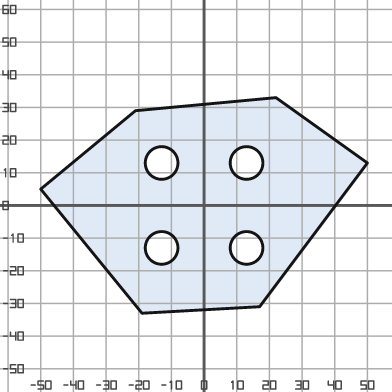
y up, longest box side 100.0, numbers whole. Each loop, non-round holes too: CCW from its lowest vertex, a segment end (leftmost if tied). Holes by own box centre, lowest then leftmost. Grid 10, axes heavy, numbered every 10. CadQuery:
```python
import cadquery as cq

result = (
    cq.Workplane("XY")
    .moveTo(-19.0, -33.0)
    .lineTo(17.0, -31.0)
    .lineTo(50.0, 13.0)
    .lineTo(22.0, 33.0)
    .lineTo(-21.0, 29.0)
    .lineTo(-50.0, 5.0)
    .close()
    .moveTo(-13.0, -13.0)
    .circle(5.0)
    .moveTo(13.0, -13.0)
    .circle(5.0)
    .moveTo(-13.0, 13.0)
    .circle(5.0)
    .moveTo(13.0, 13.0)
    .circle(5.0)
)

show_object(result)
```